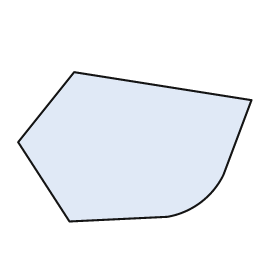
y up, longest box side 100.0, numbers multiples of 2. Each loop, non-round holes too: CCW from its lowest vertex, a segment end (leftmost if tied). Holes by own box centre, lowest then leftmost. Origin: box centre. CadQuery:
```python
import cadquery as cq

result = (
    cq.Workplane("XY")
    .moveTo(-28.0, -32.0)
    .lineTo(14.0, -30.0)
    .threePointArc((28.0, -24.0), (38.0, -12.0))
    .lineTo(50.0, 20.0)
    .lineTo(-26.0, 32.0)
    .lineTo(-50.0, 2.0)
    .close()
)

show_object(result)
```